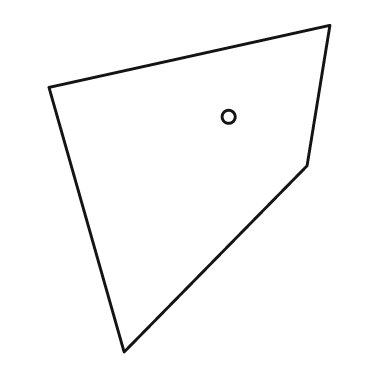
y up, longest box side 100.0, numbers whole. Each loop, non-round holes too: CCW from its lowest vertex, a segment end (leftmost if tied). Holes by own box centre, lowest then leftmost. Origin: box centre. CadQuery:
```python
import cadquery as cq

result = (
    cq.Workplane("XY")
    .moveTo(-20.0, -50.0)
    .lineTo(36.0, 7.0)
    .lineTo(43.0, 50.0)
    .lineTo(-43.0, 31.0)
    .close()
    .moveTo(12.0, 22.0)
    .circle(2.0)
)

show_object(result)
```